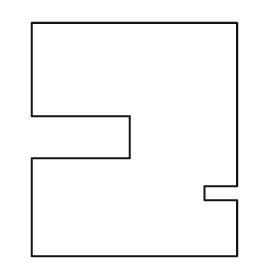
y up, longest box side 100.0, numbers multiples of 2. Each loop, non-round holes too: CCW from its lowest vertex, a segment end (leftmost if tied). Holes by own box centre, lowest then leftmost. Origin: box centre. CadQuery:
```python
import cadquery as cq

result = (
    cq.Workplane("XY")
    .moveTo(-44.0, -50.0)
    .lineTo(44.0, -50.0)
    .lineTo(44.0, -26.0)
    .lineTo(30.0, -26.0)
    .lineTo(30.0, -20.0)
    .lineTo(44.0, -20.0)
    .lineTo(44.0, 50.0)
    .lineTo(-44.0, 50.0)
    .lineTo(-44.0, 10.0)
    .lineTo(-2.0, 10.0)
    .lineTo(-2.0, -8.0)
    .lineTo(-44.0, -8.0)
    .close()
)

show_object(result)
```